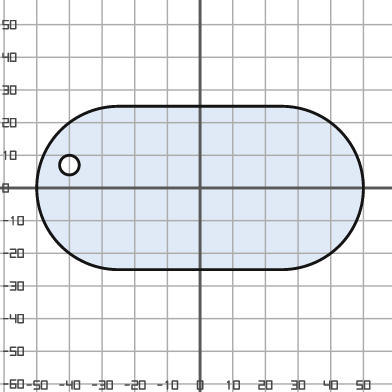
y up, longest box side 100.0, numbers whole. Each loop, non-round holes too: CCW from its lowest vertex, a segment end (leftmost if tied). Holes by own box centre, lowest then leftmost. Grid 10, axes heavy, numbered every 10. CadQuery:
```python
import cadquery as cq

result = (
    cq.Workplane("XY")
    .moveTo(-25.0, -25.0)
    .lineTo(25.0, -25.0)
    .threePointArc((50.0, 0.0), (25.0, 25.0))
    .lineTo(-25.0, 25.0)
    .threePointArc((-50.0, 0.0), (-25.0, -25.0))
    .close()
    .moveTo(-40.0, 7.0)
    .circle(3.0)
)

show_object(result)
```